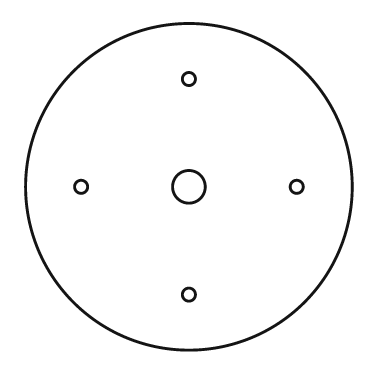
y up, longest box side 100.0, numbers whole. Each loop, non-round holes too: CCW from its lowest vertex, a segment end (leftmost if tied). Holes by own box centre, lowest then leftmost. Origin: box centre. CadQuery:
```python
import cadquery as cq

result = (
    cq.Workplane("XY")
    .moveTo(0.0, 0.0)
    .circle(50.0)
    .moveTo(0.0, -33.0)
    .circle(2.0)
    .moveTo(-33.0, 0.0)
    .circle(2.0)
    .moveTo(0.0, 0.0)
    .circle(5.0)
    .moveTo(33.0, 0.0)
    .circle(2.0)
    .moveTo(0.0, 33.0)
    .circle(2.0)
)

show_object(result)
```